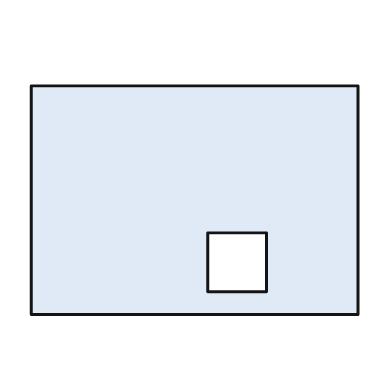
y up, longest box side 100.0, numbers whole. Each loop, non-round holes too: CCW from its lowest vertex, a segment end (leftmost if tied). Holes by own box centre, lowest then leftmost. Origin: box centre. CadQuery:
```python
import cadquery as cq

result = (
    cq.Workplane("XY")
    .moveTo(-50.0, -35.0)
    .lineTo(50.0, -35.0)
    .lineTo(50.0, 35.0)
    .lineTo(-50.0, 35.0)
    .close()
    .moveTo(4.0, -28.0)
    .lineTo(22.0, -28.0)
    .lineTo(22.0, -10.0)
    .lineTo(4.0, -10.0)
    .close()
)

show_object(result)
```